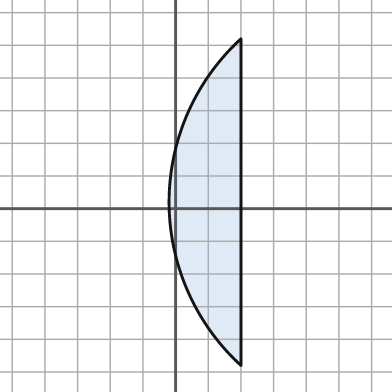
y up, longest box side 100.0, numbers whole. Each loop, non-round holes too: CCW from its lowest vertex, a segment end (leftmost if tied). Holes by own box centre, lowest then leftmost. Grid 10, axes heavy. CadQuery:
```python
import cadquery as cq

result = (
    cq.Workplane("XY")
    .moveTo(20.0, -48.0)
    .lineTo(20.0, 52.0)
    .threePointArc((-2.0, 2.0), (20.0, -48.0))
    .close()
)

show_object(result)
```